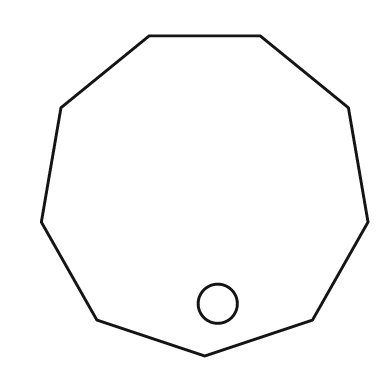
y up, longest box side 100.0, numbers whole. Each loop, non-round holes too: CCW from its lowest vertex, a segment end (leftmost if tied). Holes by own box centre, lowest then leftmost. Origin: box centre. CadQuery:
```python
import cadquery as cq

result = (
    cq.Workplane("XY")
    .moveTo(0.0, -49.0)
    .lineTo(33.0, -38.0)
    .lineTo(50.0, -8.0)
    .lineTo(44.0, 27.0)
    .lineTo(17.0, 49.0)
    .lineTo(-17.0, 49.0)
    .lineTo(-44.0, 27.0)
    .lineTo(-50.0, -8.0)
    .lineTo(-33.0, -38.0)
    .close()
    .moveTo(4.0, -33.0)
    .circle(6.0)
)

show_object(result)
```